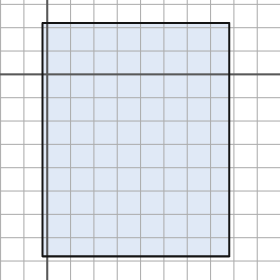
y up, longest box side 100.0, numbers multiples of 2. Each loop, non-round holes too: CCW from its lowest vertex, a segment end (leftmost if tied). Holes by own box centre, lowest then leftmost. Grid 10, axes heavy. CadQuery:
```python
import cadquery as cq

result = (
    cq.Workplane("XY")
    .moveTo(-2.0, -78.0)
    .lineTo(78.0, -78.0)
    .lineTo(78.0, 22.0)
    .lineTo(-2.0, 22.0)
    .close()
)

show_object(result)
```